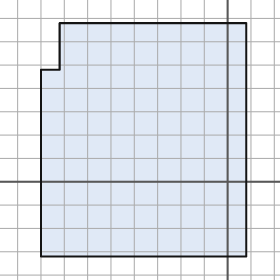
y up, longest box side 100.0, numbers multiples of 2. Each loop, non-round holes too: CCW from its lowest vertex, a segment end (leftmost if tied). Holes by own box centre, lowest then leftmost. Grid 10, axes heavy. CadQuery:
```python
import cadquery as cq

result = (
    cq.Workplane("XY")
    .moveTo(-80.0, -32.0)
    .lineTo(8.0, -32.0)
    .lineTo(8.0, 68.0)
    .lineTo(-72.0, 68.0)
    .lineTo(-72.0, 48.0)
    .lineTo(-80.0, 48.0)
    .close()
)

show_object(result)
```